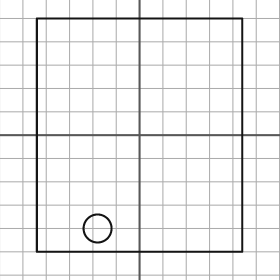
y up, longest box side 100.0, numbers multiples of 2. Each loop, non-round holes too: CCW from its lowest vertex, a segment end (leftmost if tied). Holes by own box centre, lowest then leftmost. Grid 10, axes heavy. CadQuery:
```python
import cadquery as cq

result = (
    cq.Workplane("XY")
    .moveTo(-44.0, -50.0)
    .lineTo(44.0, -50.0)
    .lineTo(44.0, 50.0)
    .lineTo(-44.0, 50.0)
    .close()
    .moveTo(-18.0, -40.0)
    .circle(6.0)
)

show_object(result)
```